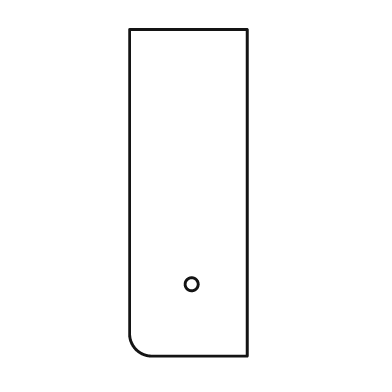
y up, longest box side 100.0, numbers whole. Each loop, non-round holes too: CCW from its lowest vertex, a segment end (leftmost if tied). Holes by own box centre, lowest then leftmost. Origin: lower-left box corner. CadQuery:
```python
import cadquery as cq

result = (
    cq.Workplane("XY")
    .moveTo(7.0, 0.0)
    .lineTo(36.0, 0.0)
    .lineTo(36.0, 100.0)
    .lineTo(0.0, 100.0)
    .lineTo(0.0, 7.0)
    .threePointArc((2.0, 2.0), (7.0, 0.0))
    .close()
    .moveTo(19.0, 22.0)
    .circle(2.0)
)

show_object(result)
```